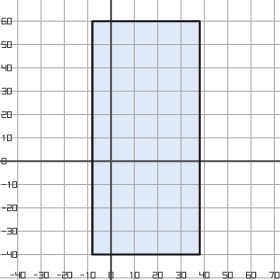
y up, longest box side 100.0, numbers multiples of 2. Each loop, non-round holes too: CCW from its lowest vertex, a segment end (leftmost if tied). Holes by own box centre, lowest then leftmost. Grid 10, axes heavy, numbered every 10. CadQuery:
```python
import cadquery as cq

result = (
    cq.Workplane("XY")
    .moveTo(-8.0, -40.0)
    .lineTo(38.0, -40.0)
    .lineTo(38.0, 60.0)
    .lineTo(-8.0, 60.0)
    .close()
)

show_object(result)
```